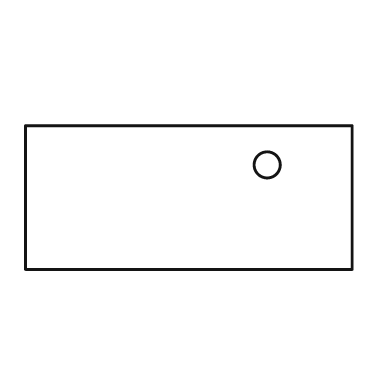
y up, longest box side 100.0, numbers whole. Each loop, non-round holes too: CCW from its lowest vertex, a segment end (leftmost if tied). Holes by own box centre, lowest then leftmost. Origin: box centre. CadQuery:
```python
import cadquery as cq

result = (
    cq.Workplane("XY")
    .moveTo(-50.0, -22.0)
    .lineTo(50.0, -22.0)
    .lineTo(50.0, 22.0)
    .lineTo(-50.0, 22.0)
    .close()
    .moveTo(24.0, 10.0)
    .circle(4.0)
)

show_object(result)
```